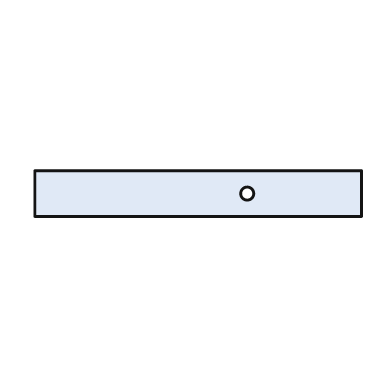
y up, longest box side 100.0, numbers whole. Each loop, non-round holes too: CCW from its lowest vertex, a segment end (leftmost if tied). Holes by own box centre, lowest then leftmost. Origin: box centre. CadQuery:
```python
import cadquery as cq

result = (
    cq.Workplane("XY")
    .moveTo(-50.0, -7.0)
    .lineTo(50.0, -7.0)
    .lineTo(50.0, 7.0)
    .lineTo(-50.0, 7.0)
    .close()
    .moveTo(15.0, 0.0)
    .circle(2.0)
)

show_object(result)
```